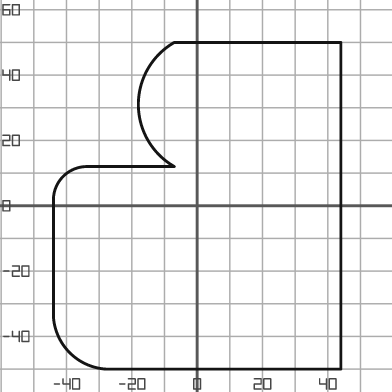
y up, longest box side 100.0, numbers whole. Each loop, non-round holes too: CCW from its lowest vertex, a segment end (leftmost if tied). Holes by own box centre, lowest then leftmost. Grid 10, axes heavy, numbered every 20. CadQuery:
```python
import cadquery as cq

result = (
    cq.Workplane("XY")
    .moveTo(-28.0, -50.0)
    .lineTo(44.0, -50.0)
    .lineTo(44.0, 50.0)
    .lineTo(-7.0, 50.0)
    .threePointArc((-18.0, 31.0), (-7.0, 12.0))
    .lineTo(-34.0, 12.0)
    .threePointArc((-41.0, 9.0), (-44.0, 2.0))
    .lineTo(-44.0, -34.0)
    .threePointArc((-39.0, -45.0), (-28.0, -50.0))
    .close()
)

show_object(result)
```